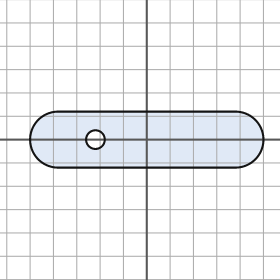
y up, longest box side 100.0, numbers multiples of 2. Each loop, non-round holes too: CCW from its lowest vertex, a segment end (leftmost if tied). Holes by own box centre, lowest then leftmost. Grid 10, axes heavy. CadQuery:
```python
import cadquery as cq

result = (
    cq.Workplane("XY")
    .moveTo(-38.0, -12.0)
    .lineTo(38.0, -12.0)
    .threePointArc((50.0, 0.0), (38.0, 12.0))
    .lineTo(-38.0, 12.0)
    .threePointArc((-50.0, 0.0), (-38.0, -12.0))
    .close()
    .moveTo(-22.0, 0.0)
    .circle(4.0)
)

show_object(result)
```